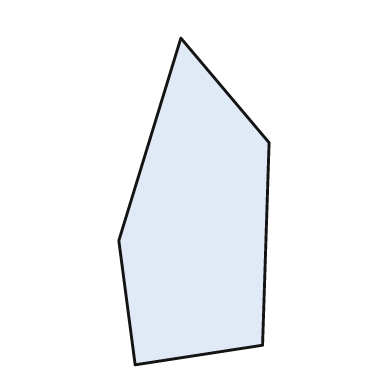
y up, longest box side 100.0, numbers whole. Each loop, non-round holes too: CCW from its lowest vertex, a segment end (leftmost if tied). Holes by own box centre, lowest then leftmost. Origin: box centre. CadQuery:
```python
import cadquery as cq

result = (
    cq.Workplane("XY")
    .moveTo(-18.0, -50.0)
    .lineTo(21.0, -44.0)
    .lineTo(23.0, 18.0)
    .lineTo(-4.0, 50.0)
    .lineTo(-23.0, -12.0)
    .close()
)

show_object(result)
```